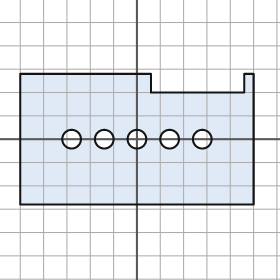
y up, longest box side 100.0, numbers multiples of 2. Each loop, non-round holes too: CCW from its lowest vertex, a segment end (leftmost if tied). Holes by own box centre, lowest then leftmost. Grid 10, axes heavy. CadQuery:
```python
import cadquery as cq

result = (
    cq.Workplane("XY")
    .moveTo(-50.0, -28.0)
    .lineTo(50.0, -28.0)
    .lineTo(50.0, 28.0)
    .lineTo(46.0, 28.0)
    .lineTo(46.0, 20.0)
    .lineTo(6.0, 20.0)
    .lineTo(6.0, 28.0)
    .lineTo(-50.0, 28.0)
    .close()
    .moveTo(-28.0, 0.0)
    .circle(4.0)
    .moveTo(-14.0, 0.0)
    .circle(4.0)
    .moveTo(0.0, 0.0)
    .circle(4.0)
    .moveTo(14.0, 0.0)
    .circle(4.0)
    .moveTo(28.0, 0.0)
    .circle(4.0)
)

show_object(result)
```